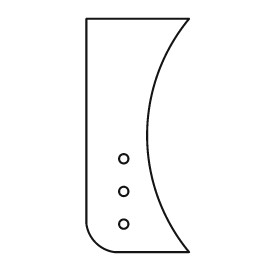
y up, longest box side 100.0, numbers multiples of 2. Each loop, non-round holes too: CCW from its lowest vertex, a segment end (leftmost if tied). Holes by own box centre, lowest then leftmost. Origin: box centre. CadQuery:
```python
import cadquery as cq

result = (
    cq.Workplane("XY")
    .moveTo(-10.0, -50.0)
    .lineTo(22.0, -50.0)
    .threePointArc((4.0, 0.0), (22.0, 50.0))
    .lineTo(-22.0, 50.0)
    .lineTo(-22.0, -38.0)
    .threePointArc((-18.0, -46.0), (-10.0, -50.0))
    .close()
    .moveTo(-6.0, -38.0)
    .circle(2.0)
    .moveTo(-6.0, -24.0)
    .circle(2.0)
    .moveTo(-6.0, -10.0)
    .circle(2.0)
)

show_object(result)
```